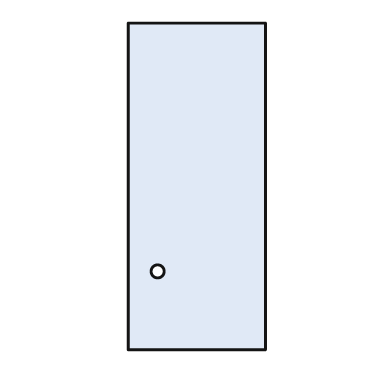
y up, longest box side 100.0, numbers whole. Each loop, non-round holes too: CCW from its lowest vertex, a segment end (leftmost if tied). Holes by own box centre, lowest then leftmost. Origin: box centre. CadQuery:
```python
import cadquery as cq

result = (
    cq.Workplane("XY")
    .moveTo(-21.0, -50.0)
    .lineTo(21.0, -50.0)
    .lineTo(21.0, 50.0)
    .lineTo(-21.0, 50.0)
    .close()
    .moveTo(-12.0, -26.0)
    .circle(2.0)
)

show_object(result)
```